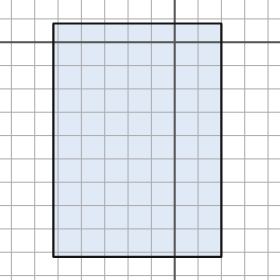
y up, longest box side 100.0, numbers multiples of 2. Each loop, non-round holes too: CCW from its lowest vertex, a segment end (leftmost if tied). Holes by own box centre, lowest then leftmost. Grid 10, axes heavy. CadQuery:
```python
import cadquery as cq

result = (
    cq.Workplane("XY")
    .moveTo(-52.0, -92.0)
    .lineTo(20.0, -92.0)
    .lineTo(20.0, 8.0)
    .lineTo(-52.0, 8.0)
    .close()
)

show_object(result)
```